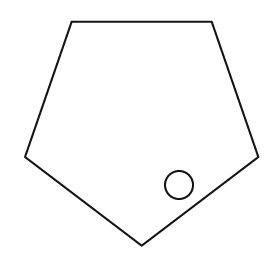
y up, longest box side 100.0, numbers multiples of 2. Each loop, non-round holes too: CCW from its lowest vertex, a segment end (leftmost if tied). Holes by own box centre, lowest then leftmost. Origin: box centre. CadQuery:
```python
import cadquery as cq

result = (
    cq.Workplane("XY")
    .moveTo(0.0, -48.0)
    .lineTo(50.0, -10.0)
    .lineTo(30.0, 48.0)
    .lineTo(-30.0, 48.0)
    .lineTo(-50.0, -10.0)
    .close()
    .moveTo(16.0, -22.0)
    .circle(6.0)
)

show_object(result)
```